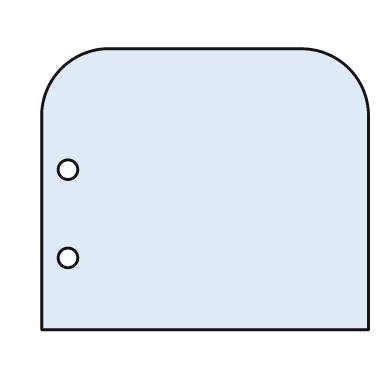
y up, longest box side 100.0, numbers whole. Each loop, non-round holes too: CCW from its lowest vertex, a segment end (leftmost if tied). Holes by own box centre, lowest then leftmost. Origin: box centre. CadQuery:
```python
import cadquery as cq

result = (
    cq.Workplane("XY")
    .moveTo(-50.0, -43.0)
    .lineTo(50.0, -43.0)
    .lineTo(50.0, 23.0)
    .threePointArc((44.0, 37.0), (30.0, 43.0))
    .lineTo(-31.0, 43.0)
    .threePointArc((-44.0, 37.0), (-50.0, 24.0))
    .close()
    .moveTo(-42.0, -21.0)
    .circle(3.0)
    .moveTo(-42.0, 6.0)
    .circle(3.0)
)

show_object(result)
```